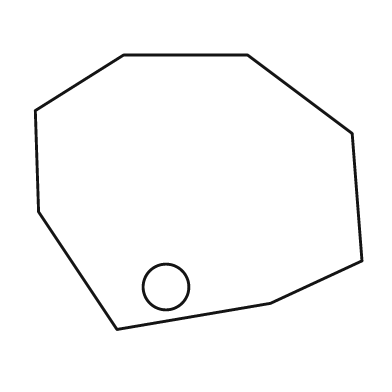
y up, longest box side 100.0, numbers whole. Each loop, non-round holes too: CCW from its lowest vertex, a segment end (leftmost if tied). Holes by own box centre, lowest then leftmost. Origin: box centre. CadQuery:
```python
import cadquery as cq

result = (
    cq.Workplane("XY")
    .moveTo(-25.0, -42.0)
    .lineTo(22.0, -34.0)
    .lineTo(50.0, -21.0)
    .lineTo(47.0, 18.0)
    .lineTo(15.0, 42.0)
    .lineTo(-23.0, 42.0)
    .lineTo(-50.0, 25.0)
    .lineTo(-49.0, -6.0)
    .close()
    .moveTo(-10.0, -29.0)
    .circle(7.0)
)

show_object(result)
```